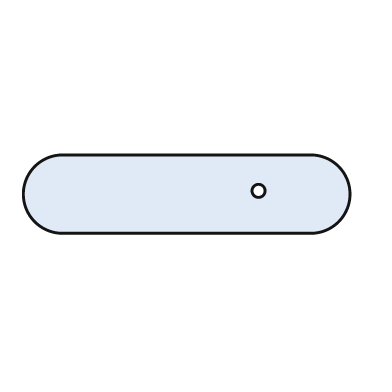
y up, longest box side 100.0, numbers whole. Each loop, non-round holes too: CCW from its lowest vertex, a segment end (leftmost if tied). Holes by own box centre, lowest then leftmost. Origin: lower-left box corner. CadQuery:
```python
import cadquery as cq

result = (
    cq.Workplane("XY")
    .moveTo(12.0, 0.0)
    .lineTo(88.0, 0.0)
    .threePointArc((100.0, 12.0), (88.0, 24.0))
    .lineTo(12.0, 24.0)
    .threePointArc((0.0, 12.0), (12.0, 0.0))
    .close()
    .moveTo(72.0, 13.0)
    .circle(2.0)
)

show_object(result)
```